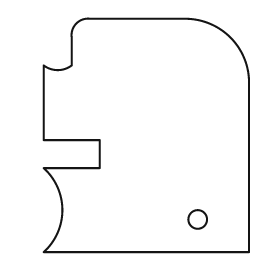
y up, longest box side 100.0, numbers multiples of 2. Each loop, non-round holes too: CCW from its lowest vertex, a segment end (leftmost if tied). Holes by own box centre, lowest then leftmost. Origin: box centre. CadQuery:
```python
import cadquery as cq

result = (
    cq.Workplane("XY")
    .moveTo(-44.0, -50.0)
    .lineTo(44.0, -50.0)
    .lineTo(44.0, 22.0)
    .threePointArc((36.0, 42.0), (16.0, 50.0))
    .lineTo(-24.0, 50.0)
    .threePointArc((-30.0, 48.0), (-32.0, 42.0))
    .lineTo(-32.0, 30.0)
    .threePointArc((-38.0, 28.0), (-44.0, 30.0))
    .lineTo(-44.0, -2.0)
    .lineTo(-20.0, -2.0)
    .lineTo(-20.0, -14.0)
    .lineTo(-44.0, -14.0)
    .threePointArc((-36.0, -32.0), (-44.0, -50.0))
    .close()
    .moveTo(22.0, -36.0)
    .circle(4.0)
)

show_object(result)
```